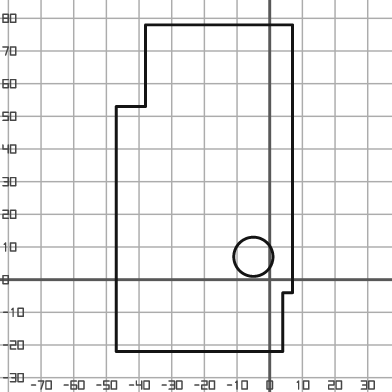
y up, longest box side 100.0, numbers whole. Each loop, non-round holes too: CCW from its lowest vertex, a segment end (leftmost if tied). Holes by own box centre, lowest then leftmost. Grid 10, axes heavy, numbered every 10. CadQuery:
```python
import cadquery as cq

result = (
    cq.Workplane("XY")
    .moveTo(-47.0, -22.0)
    .lineTo(4.0, -22.0)
    .lineTo(4.0, -4.0)
    .lineTo(7.0, -4.0)
    .lineTo(7.0, 78.0)
    .lineTo(-38.0, 78.0)
    .lineTo(-38.0, 53.0)
    .lineTo(-47.0, 53.0)
    .close()
    .moveTo(-5.0, 7.0)
    .circle(6.0)
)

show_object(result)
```